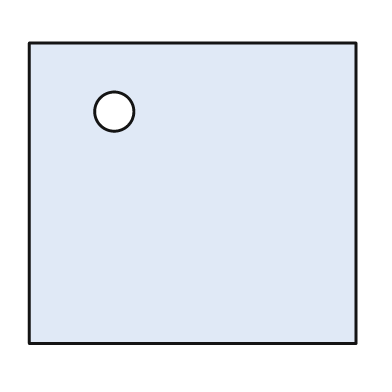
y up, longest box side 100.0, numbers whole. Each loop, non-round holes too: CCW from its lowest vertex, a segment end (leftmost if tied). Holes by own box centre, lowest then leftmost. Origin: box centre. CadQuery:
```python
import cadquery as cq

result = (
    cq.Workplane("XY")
    .moveTo(-50.0, -46.0)
    .lineTo(50.0, -46.0)
    .lineTo(50.0, 46.0)
    .lineTo(-50.0, 46.0)
    .close()
    .moveTo(-24.0, 25.0)
    .circle(6.0)
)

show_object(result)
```